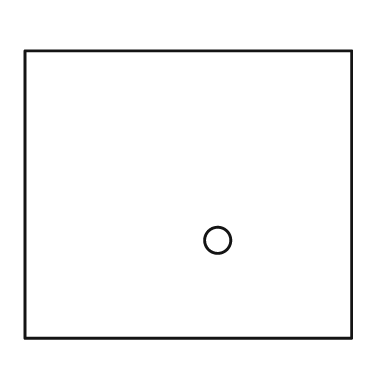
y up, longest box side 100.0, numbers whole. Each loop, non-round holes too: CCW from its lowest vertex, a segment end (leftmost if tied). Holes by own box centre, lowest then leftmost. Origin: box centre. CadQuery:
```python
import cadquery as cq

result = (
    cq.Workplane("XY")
    .moveTo(-50.0, -44.0)
    .lineTo(50.0, -44.0)
    .lineTo(50.0, 44.0)
    .lineTo(-50.0, 44.0)
    .close()
    .moveTo(9.0, -14.0)
    .circle(4.0)
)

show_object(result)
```